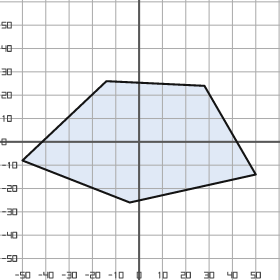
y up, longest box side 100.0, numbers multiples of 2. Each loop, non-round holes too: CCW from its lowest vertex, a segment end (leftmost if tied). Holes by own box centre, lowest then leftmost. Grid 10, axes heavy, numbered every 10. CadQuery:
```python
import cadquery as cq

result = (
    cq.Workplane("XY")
    .moveTo(-4.0, -26.0)
    .lineTo(50.0, -14.0)
    .lineTo(28.0, 24.0)
    .lineTo(-14.0, 26.0)
    .lineTo(-50.0, -8.0)
    .close()
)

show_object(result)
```